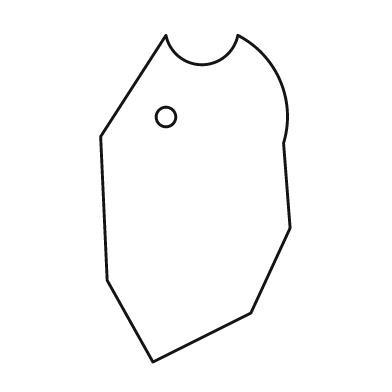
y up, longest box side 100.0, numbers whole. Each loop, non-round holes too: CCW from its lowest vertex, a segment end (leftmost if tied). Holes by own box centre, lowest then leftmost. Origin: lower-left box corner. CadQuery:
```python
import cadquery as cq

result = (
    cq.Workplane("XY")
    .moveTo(16.0, 0.0)
    .lineTo(46.0, 15.0)
    .lineTo(58.0, 41.0)
    .lineTo(56.0, 67.0)
    .threePointArc((55.0, 86.0), (42.0, 100.0))
    .threePointArc((31.0, 91.0), (20.0, 100.0))
    .lineTo(0.0, 69.0)
    .lineTo(2.0, 25.0)
    .close()
    .moveTo(20.0, 75.0)
    .circle(3.0)
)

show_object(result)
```